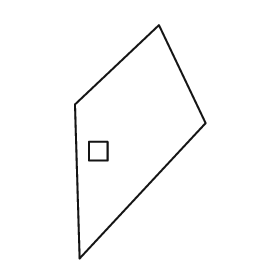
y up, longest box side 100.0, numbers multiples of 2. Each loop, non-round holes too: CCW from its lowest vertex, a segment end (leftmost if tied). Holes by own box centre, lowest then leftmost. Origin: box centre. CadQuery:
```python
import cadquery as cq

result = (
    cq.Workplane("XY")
    .moveTo(-26.0, -50.0)
    .lineTo(28.0, 8.0)
    .lineTo(8.0, 50.0)
    .lineTo(-28.0, 16.0)
    .close()
    .moveTo(-22.0, -8.0)
    .lineTo(-14.0, -8.0)
    .lineTo(-14.0, 0.0)
    .lineTo(-22.0, 0.0)
    .close()
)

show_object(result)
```